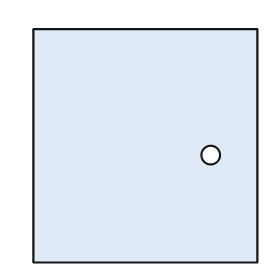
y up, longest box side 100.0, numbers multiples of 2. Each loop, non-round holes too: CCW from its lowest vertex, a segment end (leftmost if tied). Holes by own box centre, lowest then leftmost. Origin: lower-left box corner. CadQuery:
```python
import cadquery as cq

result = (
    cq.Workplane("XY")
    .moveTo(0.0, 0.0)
    .lineTo(96.0, 0.0)
    .lineTo(96.0, 100.0)
    .lineTo(0.0, 100.0)
    .close()
    .moveTo(76.0, 46.0)
    .circle(4.0)
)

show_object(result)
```